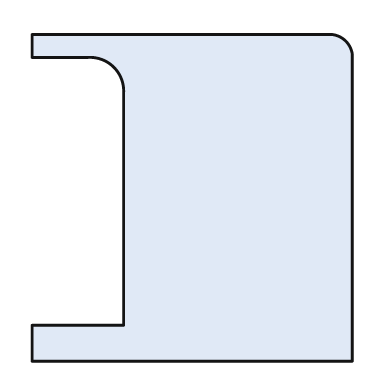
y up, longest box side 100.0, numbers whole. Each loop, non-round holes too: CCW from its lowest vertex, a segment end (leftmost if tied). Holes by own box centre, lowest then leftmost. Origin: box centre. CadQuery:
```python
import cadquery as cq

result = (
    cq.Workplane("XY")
    .moveTo(-49.0, -50.0)
    .lineTo(49.0, -50.0)
    .lineTo(49.0, 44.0)
    .threePointArc((47.0, 48.0), (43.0, 50.0))
    .lineTo(-49.0, 50.0)
    .lineTo(-49.0, 43.0)
    .lineTo(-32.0, 43.0)
    .threePointArc((-24.0, 40.0), (-21.0, 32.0))
    .lineTo(-21.0, -39.0)
    .lineTo(-49.0, -39.0)
    .close()
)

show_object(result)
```